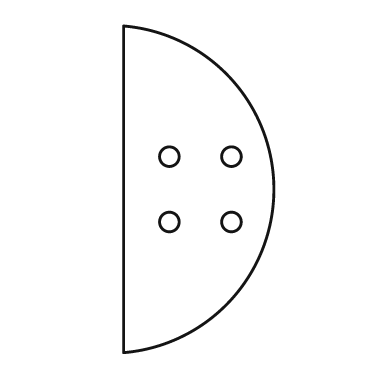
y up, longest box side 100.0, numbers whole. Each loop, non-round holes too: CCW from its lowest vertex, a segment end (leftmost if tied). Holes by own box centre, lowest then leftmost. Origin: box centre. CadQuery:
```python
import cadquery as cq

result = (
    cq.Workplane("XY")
    .moveTo(-23.0, -50.0)
    .threePointArc((23.0, 0.0), (-23.0, 50.0))
    .close()
    .moveTo(-9.0, -10.0)
    .circle(3.0)
    .moveTo(10.0, -10.0)
    .circle(3.0)
    .moveTo(-9.0, 10.0)
    .circle(3.0)
    .moveTo(10.0, 10.0)
    .circle(3.0)
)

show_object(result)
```